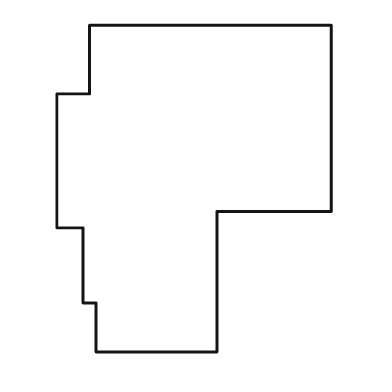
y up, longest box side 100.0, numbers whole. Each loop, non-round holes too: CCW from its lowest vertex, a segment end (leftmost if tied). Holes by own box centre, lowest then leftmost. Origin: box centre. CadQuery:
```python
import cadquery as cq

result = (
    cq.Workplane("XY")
    .moveTo(-30.0, -50.0)
    .lineTo(7.0, -50.0)
    .lineTo(7.0, -7.0)
    .lineTo(42.0, -7.0)
    .lineTo(42.0, 50.0)
    .lineTo(-32.0, 50.0)
    .lineTo(-32.0, 29.0)
    .lineTo(-42.0, 29.0)
    .lineTo(-42.0, -12.0)
    .lineTo(-34.0, -12.0)
    .lineTo(-34.0, -35.0)
    .lineTo(-30.0, -35.0)
    .close()
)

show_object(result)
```